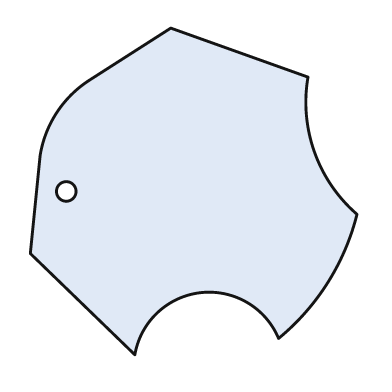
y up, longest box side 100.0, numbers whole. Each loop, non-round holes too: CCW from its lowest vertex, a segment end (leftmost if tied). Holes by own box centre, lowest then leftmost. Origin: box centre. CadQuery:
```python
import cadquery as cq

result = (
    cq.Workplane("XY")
    .moveTo(-18.0, -50.0)
    .threePointArc((2.0, -31.0), (26.0, -45.0))
    .threePointArc((41.0, -28.0), (50.0, -7.0))
    .threePointArc((37.0, 12.0), (35.0, 35.0))
    .lineTo(-7.0, 50.0)
    .lineTo(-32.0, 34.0)
    .threePointArc((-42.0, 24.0), (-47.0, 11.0))
    .lineTo(-50.0, -19.0)
    .close()
    .moveTo(-39.0, 0.0)
    .circle(3.0)
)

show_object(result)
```